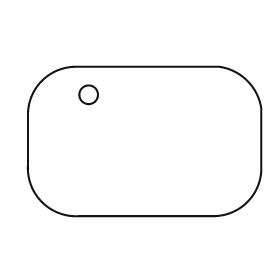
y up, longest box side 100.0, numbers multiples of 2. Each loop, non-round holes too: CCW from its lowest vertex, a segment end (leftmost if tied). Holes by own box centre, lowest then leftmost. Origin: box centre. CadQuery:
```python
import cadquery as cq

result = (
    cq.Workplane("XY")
    .moveTo(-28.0, -32.0)
    .lineTo(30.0, -32.0)
    .threePointArc((44.0, -26.0), (50.0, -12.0))
    .lineTo(50.0, 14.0)
    .threePointArc((44.0, 26.0), (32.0, 32.0))
    .lineTo(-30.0, 32.0)
    .threePointArc((-44.0, 26.0), (-50.0, 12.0))
    .lineTo(-50.0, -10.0)
    .threePointArc((-44.0, -26.0), (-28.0, -32.0))
    .close()
    .moveTo(-24.0, 20.0)
    .circle(4.0)
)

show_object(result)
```